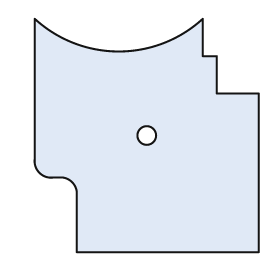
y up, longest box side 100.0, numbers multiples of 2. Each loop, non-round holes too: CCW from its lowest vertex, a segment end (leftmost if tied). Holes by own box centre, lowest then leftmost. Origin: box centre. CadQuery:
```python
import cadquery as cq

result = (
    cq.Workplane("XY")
    .moveTo(-30.0, -50.0)
    .lineTo(48.0, -50.0)
    .lineTo(48.0, 18.0)
    .lineTo(30.0, 18.0)
    .lineTo(30.0, 34.0)
    .lineTo(24.0, 34.0)
    .lineTo(24.0, 50.0)
    .threePointArc((-12.0, 36.0), (-48.0, 50.0))
    .lineTo(-48.0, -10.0)
    .threePointArc((-46.0, -16.0), (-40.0, -18.0))
    .lineTo(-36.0, -18.0)
    .threePointArc((-32.0, -20.0), (-30.0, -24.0))
    .close()
    .moveTo(0.0, 0.0)
    .circle(4.0)
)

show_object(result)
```